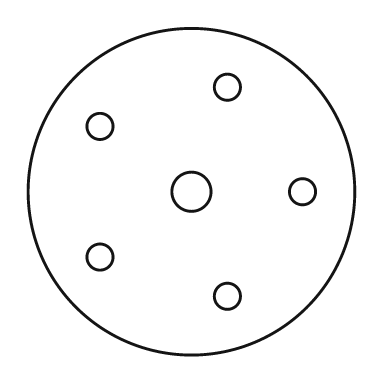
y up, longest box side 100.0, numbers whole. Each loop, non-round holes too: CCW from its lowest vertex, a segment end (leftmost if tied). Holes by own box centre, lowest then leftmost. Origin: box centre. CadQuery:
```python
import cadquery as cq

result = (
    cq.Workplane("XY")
    .moveTo(0.0, 0.0)
    .circle(50.0)
    .moveTo(11.0, -32.0)
    .circle(4.0)
    .moveTo(-28.0, -20.0)
    .circle(4.0)
    .moveTo(0.0, 0.0)
    .circle(6.0)
    .moveTo(34.0, 0.0)
    .circle(4.0)
    .moveTo(-28.0, 20.0)
    .circle(4.0)
    .moveTo(11.0, 32.0)
    .circle(4.0)
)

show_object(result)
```